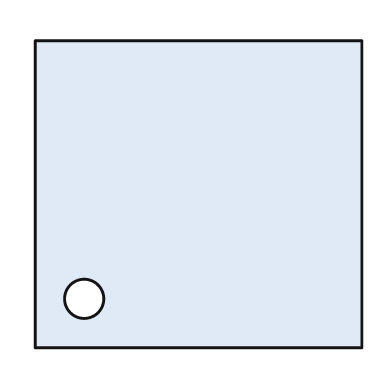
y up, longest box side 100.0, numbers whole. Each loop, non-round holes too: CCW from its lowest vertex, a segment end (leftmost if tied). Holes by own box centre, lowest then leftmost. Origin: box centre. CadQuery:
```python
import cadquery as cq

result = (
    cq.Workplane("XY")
    .moveTo(-50.0, -47.0)
    .lineTo(50.0, -47.0)
    .lineTo(50.0, 47.0)
    .lineTo(-50.0, 47.0)
    .close()
    .moveTo(-35.0, -32.0)
    .circle(6.0)
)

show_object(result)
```